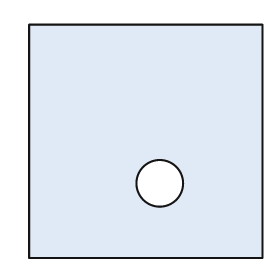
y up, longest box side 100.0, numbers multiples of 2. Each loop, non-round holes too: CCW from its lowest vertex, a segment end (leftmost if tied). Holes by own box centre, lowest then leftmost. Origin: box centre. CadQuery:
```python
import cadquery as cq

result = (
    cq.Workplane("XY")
    .moveTo(-50.0, -50.0)
    .lineTo(50.0, -50.0)
    .lineTo(50.0, 50.0)
    .lineTo(-50.0, 50.0)
    .close()
    .moveTo(6.0, -18.0)
    .circle(10.0)
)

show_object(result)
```